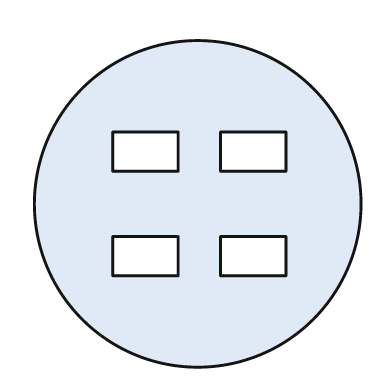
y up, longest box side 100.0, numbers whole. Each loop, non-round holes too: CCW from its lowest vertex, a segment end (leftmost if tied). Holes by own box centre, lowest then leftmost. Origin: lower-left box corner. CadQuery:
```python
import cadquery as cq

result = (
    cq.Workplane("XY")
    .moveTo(50.0, 50.0)
    .circle(50.0)
    .moveTo(24.0, 28.0)
    .lineTo(44.0, 28.0)
    .lineTo(44.0, 40.0)
    .lineTo(24.0, 40.0)
    .close()
    .moveTo(57.0, 28.0)
    .lineTo(77.0, 28.0)
    .lineTo(77.0, 40.0)
    .lineTo(57.0, 40.0)
    .close()
    .moveTo(24.0, 60.0)
    .lineTo(44.0, 60.0)
    .lineTo(44.0, 72.0)
    .lineTo(24.0, 72.0)
    .close()
    .moveTo(57.0, 60.0)
    .lineTo(77.0, 60.0)
    .lineTo(77.0, 72.0)
    .lineTo(57.0, 72.0)
    .close()
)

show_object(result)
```